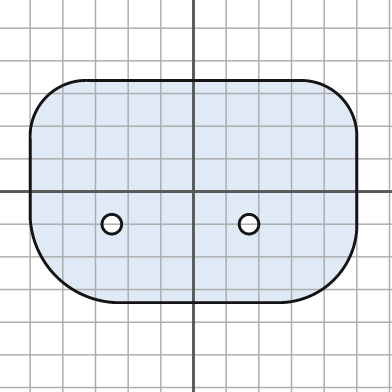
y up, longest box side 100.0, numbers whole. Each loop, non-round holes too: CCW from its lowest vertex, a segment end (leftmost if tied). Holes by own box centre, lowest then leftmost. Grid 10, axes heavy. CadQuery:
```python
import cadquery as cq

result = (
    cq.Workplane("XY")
    .moveTo(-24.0, -34.0)
    .lineTo(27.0, -34.0)
    .threePointArc((43.0, -27.0), (50.0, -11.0))
    .lineTo(50.0, 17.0)
    .threePointArc((45.0, 29.0), (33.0, 34.0))
    .lineTo(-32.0, 34.0)
    .threePointArc((-45.0, 29.0), (-50.0, 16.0))
    .lineTo(-50.0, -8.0)
    .threePointArc((-42.0, -26.0), (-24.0, -34.0))
    .close()
    .moveTo(-25.0, -10.0)
    .circle(3.0)
    .moveTo(17.0, -10.0)
    .circle(3.0)
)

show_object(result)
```